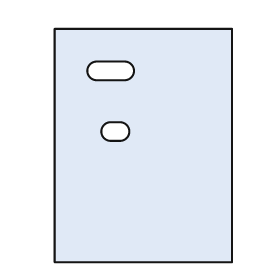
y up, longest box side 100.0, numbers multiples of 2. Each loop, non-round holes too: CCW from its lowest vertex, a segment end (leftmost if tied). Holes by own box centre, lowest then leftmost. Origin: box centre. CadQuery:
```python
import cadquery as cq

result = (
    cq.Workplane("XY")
    .moveTo(-38.0, -50.0)
    .lineTo(38.0, -50.0)
    .lineTo(38.0, 50.0)
    .lineTo(-38.0, 50.0)
    .close()
    .moveTo(-14.0, 2.0)
    .lineTo(-10.0, 2.0)
    .threePointArc((-6.0, 6.0), (-10.0, 10.0))
    .lineTo(-14.0, 10.0)
    .threePointArc((-18.0, 6.0), (-14.0, 2.0))
    .close()
    .moveTo(-20.0, 28.0)
    .lineTo(-8.0, 28.0)
    .threePointArc((-4.0, 32.0), (-8.0, 36.0))
    .lineTo(-20.0, 36.0)
    .threePointArc((-24.0, 32.0), (-20.0, 28.0))
    .close()
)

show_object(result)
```